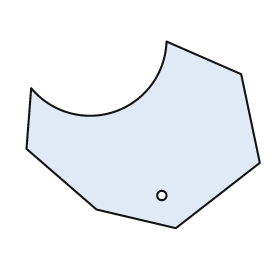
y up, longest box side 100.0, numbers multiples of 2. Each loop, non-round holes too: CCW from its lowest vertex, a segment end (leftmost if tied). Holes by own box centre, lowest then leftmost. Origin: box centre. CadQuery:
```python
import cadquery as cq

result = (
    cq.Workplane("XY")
    .moveTo(14.0, -40.0)
    .lineTo(50.0, -12.0)
    .lineTo(42.0, 26.0)
    .lineTo(10.0, 40.0)
    .threePointArc((-12.0, 10.0), (-48.0, 20.0))
    .lineTo(-50.0, -6.0)
    .lineTo(-20.0, -32.0)
    .close()
    .moveTo(8.0, -26.0)
    .circle(2.0)
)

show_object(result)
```